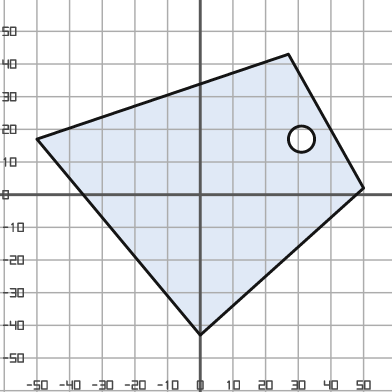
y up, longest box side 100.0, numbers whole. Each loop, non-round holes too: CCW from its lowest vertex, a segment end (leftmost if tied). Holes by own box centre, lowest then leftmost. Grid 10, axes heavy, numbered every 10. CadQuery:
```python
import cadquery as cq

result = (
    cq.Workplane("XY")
    .moveTo(0.0, -43.0)
    .lineTo(50.0, 2.0)
    .lineTo(27.0, 43.0)
    .lineTo(-50.0, 17.0)
    .close()
    .moveTo(31.0, 17.0)
    .circle(4.0)
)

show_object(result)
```